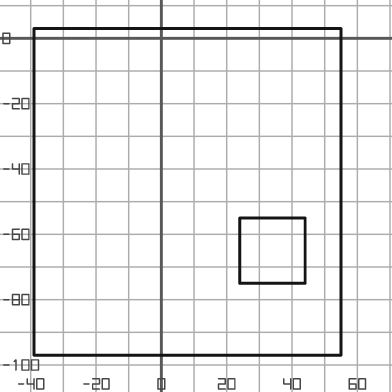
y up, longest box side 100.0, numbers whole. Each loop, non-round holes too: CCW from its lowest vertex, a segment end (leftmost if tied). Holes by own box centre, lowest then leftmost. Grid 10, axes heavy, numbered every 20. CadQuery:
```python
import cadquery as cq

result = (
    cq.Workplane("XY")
    .moveTo(-39.0, -97.0)
    .lineTo(55.0, -97.0)
    .lineTo(55.0, 3.0)
    .lineTo(-39.0, 3.0)
    .close()
    .moveTo(24.0, -75.0)
    .lineTo(44.0, -75.0)
    .lineTo(44.0, -55.0)
    .lineTo(24.0, -55.0)
    .close()
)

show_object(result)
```